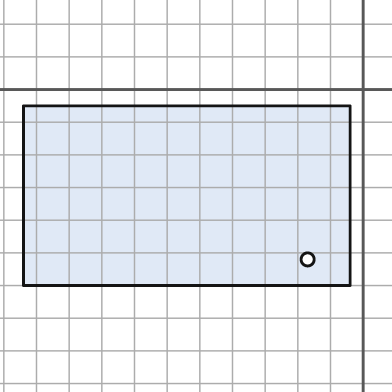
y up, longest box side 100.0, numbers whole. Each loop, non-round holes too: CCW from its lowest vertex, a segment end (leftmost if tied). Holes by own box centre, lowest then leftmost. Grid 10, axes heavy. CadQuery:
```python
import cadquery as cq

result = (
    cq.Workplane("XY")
    .moveTo(-104.0, -60.0)
    .lineTo(-4.0, -60.0)
    .lineTo(-4.0, -5.0)
    .lineTo(-104.0, -5.0)
    .close()
    .moveTo(-17.0, -52.0)
    .circle(2.0)
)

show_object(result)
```